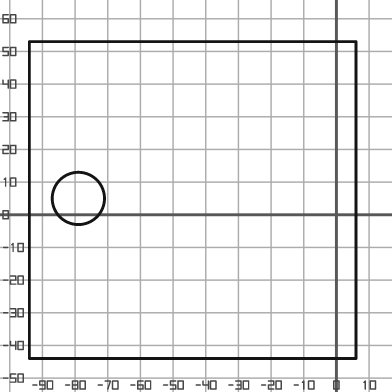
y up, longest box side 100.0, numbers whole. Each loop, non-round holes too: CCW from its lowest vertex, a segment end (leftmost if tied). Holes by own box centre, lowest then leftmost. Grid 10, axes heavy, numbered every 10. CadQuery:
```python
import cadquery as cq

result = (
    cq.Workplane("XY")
    .moveTo(-94.0, -44.0)
    .lineTo(6.0, -44.0)
    .lineTo(6.0, 53.0)
    .lineTo(-94.0, 53.0)
    .close()
    .moveTo(-79.0, 5.0)
    .circle(8.0)
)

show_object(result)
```